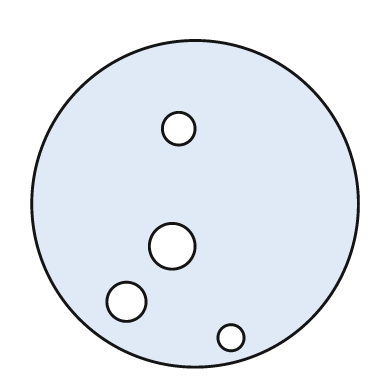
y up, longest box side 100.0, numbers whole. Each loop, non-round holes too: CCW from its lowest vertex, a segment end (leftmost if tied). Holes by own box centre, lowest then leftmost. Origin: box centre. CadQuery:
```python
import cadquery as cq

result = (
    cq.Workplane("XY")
    .moveTo(0.0, 0.0)
    .circle(50.0)
    .moveTo(11.0, -41.0)
    .circle(4.0)
    .moveTo(-21.0, -30.0)
    .circle(6.0)
    .moveTo(-7.0, -13.0)
    .circle(7.0)
    .moveTo(-5.0, 23.0)
    .circle(5.0)
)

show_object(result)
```